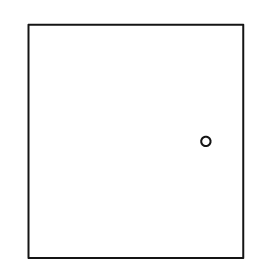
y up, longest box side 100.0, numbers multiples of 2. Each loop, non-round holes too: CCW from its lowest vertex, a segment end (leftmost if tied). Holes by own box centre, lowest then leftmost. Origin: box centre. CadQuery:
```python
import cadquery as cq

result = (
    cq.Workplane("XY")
    .moveTo(-46.0, -50.0)
    .lineTo(46.0, -50.0)
    .lineTo(46.0, 50.0)
    .lineTo(-46.0, 50.0)
    .close()
    .moveTo(30.0, 0.0)
    .circle(2.0)
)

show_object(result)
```